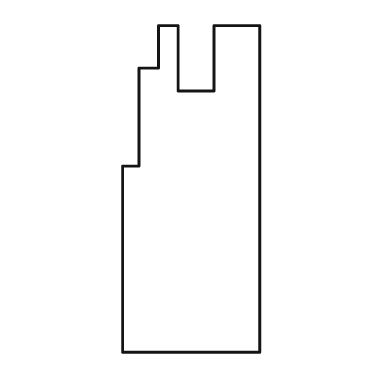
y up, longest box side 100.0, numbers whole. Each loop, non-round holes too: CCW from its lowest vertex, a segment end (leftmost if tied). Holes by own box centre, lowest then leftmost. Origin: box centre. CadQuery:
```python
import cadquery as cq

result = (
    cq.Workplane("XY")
    .moveTo(-21.0, -50.0)
    .lineTo(21.0, -50.0)
    .lineTo(21.0, 50.0)
    .lineTo(7.0, 50.0)
    .lineTo(7.0, 30.0)
    .lineTo(-4.0, 30.0)
    .lineTo(-4.0, 50.0)
    .lineTo(-10.0, 50.0)
    .lineTo(-10.0, 37.0)
    .lineTo(-16.0, 37.0)
    .lineTo(-16.0, 7.0)
    .lineTo(-21.0, 7.0)
    .close()
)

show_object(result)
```